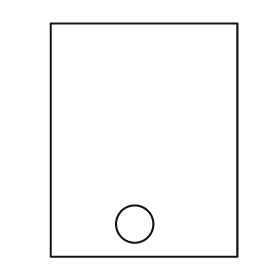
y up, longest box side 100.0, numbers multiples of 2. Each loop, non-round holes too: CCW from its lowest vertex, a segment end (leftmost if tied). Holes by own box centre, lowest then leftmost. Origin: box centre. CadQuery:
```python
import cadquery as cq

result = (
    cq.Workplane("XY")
    .moveTo(-40.0, -50.0)
    .lineTo(40.0, -50.0)
    .lineTo(40.0, 50.0)
    .lineTo(-40.0, 50.0)
    .close()
    .moveTo(-4.0, -36.0)
    .circle(8.0)
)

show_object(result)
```